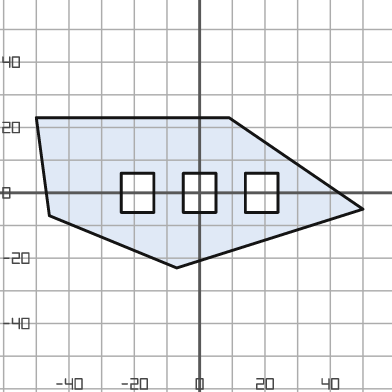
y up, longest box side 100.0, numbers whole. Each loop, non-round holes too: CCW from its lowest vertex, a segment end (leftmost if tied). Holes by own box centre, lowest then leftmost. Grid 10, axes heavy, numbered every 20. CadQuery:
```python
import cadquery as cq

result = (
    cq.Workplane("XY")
    .moveTo(-7.0, -23.0)
    .lineTo(50.0, -5.0)
    .lineTo(9.0, 23.0)
    .lineTo(-50.0, 23.0)
    .lineTo(-46.0, -7.0)
    .close()
    .moveTo(-24.0, -6.0)
    .lineTo(-14.0, -6.0)
    .lineTo(-14.0, 6.0)
    .lineTo(-24.0, 6.0)
    .close()
    .moveTo(-5.0, -6.0)
    .lineTo(5.0, -6.0)
    .lineTo(5.0, 6.0)
    .lineTo(-5.0, 6.0)
    .close()
    .moveTo(14.0, -6.0)
    .lineTo(24.0, -6.0)
    .lineTo(24.0, 6.0)
    .lineTo(14.0, 6.0)
    .close()
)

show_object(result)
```